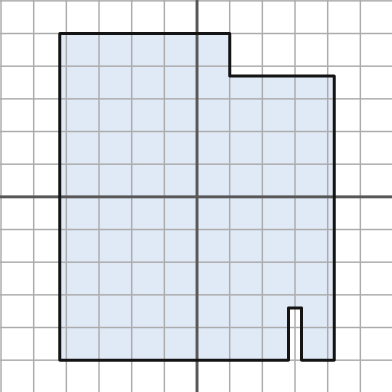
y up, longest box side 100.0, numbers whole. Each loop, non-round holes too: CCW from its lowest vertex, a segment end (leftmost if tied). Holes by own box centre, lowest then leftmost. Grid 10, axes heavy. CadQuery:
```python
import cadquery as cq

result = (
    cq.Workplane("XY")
    .moveTo(-42.0, -50.0)
    .lineTo(28.0, -50.0)
    .lineTo(28.0, -34.0)
    .lineTo(32.0, -34.0)
    .lineTo(32.0, -50.0)
    .lineTo(42.0, -50.0)
    .lineTo(42.0, 37.0)
    .lineTo(10.0, 37.0)
    .lineTo(10.0, 50.0)
    .lineTo(-42.0, 50.0)
    .close()
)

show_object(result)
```